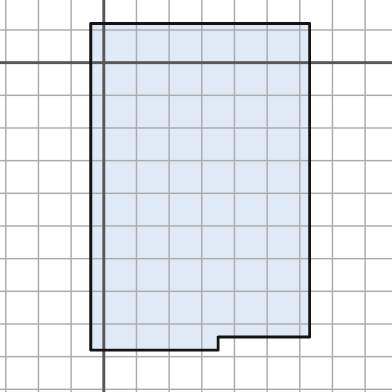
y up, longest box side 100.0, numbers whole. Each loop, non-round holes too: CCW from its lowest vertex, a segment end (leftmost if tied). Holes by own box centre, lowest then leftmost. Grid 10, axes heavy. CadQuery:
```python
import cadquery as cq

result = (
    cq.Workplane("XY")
    .moveTo(-4.0, -88.0)
    .lineTo(35.0, -88.0)
    .lineTo(35.0, -84.0)
    .lineTo(63.0, -84.0)
    .lineTo(63.0, 12.0)
    .lineTo(-4.0, 12.0)
    .close()
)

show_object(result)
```